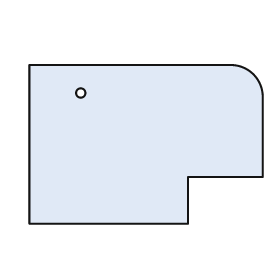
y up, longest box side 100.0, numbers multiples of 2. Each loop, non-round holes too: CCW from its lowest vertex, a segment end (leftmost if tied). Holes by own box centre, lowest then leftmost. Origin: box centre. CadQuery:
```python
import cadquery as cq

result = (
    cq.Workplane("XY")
    .moveTo(-50.0, -34.0)
    .lineTo(18.0, -34.0)
    .lineTo(18.0, -14.0)
    .lineTo(50.0, -14.0)
    .lineTo(50.0, 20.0)
    .threePointArc((46.0, 30.0), (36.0, 34.0))
    .lineTo(-50.0, 34.0)
    .close()
    .moveTo(-28.0, 22.0)
    .circle(2.0)
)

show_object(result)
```